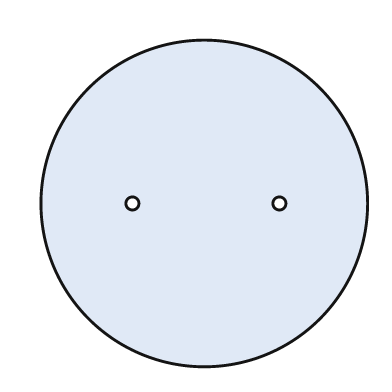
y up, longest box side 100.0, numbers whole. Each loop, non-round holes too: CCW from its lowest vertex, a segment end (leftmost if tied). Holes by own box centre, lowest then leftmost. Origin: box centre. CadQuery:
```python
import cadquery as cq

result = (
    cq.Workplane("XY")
    .moveTo(0.0, 0.0)
    .circle(50.0)
    .moveTo(-22.0, 0.0)
    .circle(2.0)
    .moveTo(23.0, 0.0)
    .circle(2.0)
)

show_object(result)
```